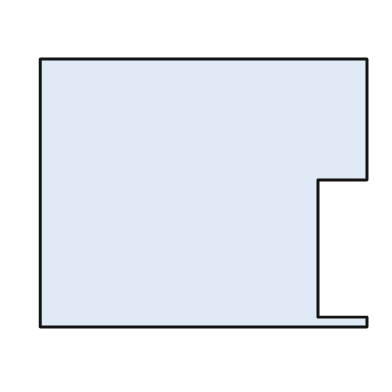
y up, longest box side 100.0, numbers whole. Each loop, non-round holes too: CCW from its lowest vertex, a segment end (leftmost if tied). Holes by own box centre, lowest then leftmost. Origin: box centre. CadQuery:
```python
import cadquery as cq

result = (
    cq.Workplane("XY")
    .moveTo(-50.0, -41.0)
    .lineTo(50.0, -41.0)
    .lineTo(50.0, -38.0)
    .lineTo(35.0, -38.0)
    .lineTo(35.0, 4.0)
    .lineTo(50.0, 4.0)
    .lineTo(50.0, 41.0)
    .lineTo(-50.0, 41.0)
    .close()
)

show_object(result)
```